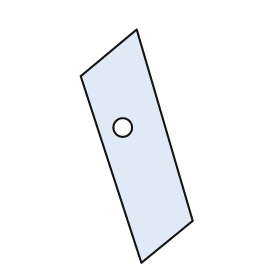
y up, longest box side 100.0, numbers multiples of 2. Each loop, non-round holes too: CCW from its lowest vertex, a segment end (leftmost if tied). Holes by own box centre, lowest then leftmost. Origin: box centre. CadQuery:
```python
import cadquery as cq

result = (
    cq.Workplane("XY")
    .moveTo(2.0, -50.0)
    .lineTo(24.0, -32.0)
    .lineTo(0.0, 50.0)
    .lineTo(-24.0, 30.0)
    .close()
    .moveTo(-6.0, 8.0)
    .circle(4.0)
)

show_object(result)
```